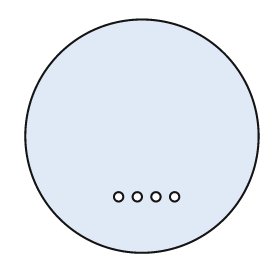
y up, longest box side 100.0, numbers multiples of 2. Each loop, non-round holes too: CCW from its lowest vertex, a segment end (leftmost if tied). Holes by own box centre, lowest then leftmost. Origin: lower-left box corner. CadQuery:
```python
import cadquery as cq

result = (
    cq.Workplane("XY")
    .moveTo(50.0, 50.0)
    .circle(50.0)
    .moveTo(40.0, 24.0)
    .circle(2.0)
    .moveTo(48.0, 24.0)
    .circle(2.0)
    .moveTo(56.0, 24.0)
    .circle(2.0)
    .moveTo(64.0, 24.0)
    .circle(2.0)
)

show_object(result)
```